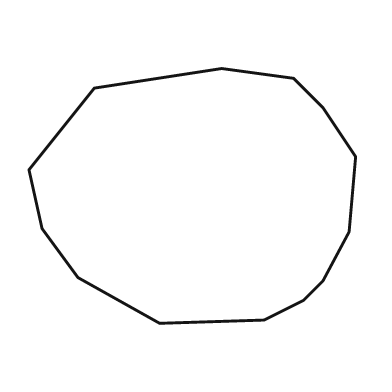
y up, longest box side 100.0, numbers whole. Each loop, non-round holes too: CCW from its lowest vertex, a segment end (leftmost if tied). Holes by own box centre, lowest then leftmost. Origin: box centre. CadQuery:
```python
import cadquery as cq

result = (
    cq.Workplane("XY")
    .moveTo(-10.0, -39.0)
    .lineTo(22.0, -38.0)
    .lineTo(34.0, -32.0)
    .lineTo(40.0, -26.0)
    .lineTo(48.0, -11.0)
    .lineTo(50.0, 12.0)
    .lineTo(40.0, 27.0)
    .lineTo(31.0, 36.0)
    .lineTo(9.0, 39.0)
    .lineTo(-30.0, 33.0)
    .lineTo(-50.0, 8.0)
    .lineTo(-46.0, -10.0)
    .lineTo(-35.0, -25.0)
    .close()
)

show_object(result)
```